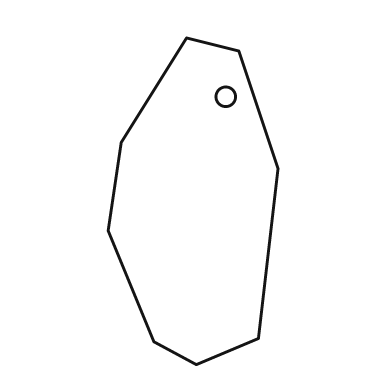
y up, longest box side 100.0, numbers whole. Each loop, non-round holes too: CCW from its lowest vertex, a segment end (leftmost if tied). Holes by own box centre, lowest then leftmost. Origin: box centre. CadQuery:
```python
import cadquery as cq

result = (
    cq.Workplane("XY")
    .moveTo(1.0, -50.0)
    .lineTo(20.0, -42.0)
    .lineTo(26.0, 10.0)
    .lineTo(14.0, 46.0)
    .lineTo(-2.0, 50.0)
    .lineTo(-22.0, 18.0)
    .lineTo(-26.0, -9.0)
    .lineTo(-12.0, -43.0)
    .close()
    .moveTo(10.0, 32.0)
    .circle(3.0)
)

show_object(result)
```